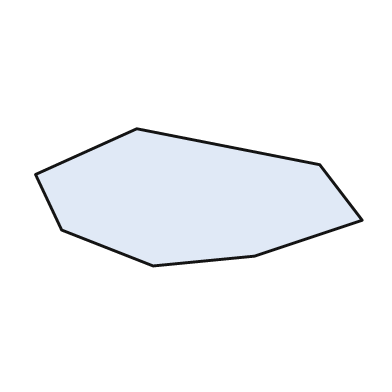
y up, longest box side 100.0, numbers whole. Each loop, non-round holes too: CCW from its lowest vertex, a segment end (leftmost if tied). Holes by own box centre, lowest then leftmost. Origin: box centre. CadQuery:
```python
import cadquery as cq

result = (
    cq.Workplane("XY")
    .moveTo(-14.0, -21.0)
    .lineTo(17.0, -18.0)
    .lineTo(50.0, -7.0)
    .lineTo(37.0, 10.0)
    .lineTo(-19.0, 21.0)
    .lineTo(-50.0, 7.0)
    .lineTo(-42.0, -10.0)
    .close()
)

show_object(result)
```